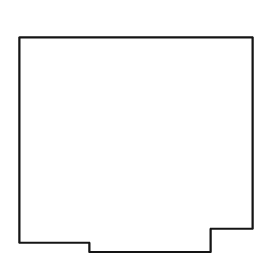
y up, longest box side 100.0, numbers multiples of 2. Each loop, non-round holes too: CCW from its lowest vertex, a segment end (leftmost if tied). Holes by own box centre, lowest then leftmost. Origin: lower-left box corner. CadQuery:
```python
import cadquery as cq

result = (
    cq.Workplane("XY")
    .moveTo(30.0, 0.0)
    .lineTo(82.0, 0.0)
    .lineTo(82.0, 10.0)
    .lineTo(100.0, 10.0)
    .lineTo(100.0, 92.0)
    .lineTo(0.0, 92.0)
    .lineTo(0.0, 4.0)
    .lineTo(30.0, 4.0)
    .close()
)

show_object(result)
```